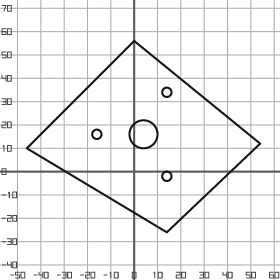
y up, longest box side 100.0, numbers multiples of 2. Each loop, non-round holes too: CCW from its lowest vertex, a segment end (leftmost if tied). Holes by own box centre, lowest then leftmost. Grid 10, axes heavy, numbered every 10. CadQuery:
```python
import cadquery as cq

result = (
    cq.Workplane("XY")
    .moveTo(14.0, -26.0)
    .lineTo(54.0, 12.0)
    .lineTo(0.0, 56.0)
    .lineTo(-46.0, 10.0)
    .close()
    .moveTo(14.0, -2.0)
    .circle(2.0)
    .moveTo(-16.0, 16.0)
    .circle(2.0)
    .moveTo(4.0, 16.0)
    .circle(6.0)
    .moveTo(14.0, 34.0)
    .circle(2.0)
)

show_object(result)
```